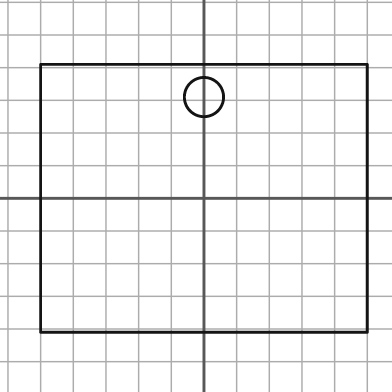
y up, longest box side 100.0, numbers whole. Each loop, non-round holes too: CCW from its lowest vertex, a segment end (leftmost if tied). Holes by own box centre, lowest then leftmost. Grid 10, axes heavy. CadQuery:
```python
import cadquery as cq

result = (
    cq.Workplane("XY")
    .moveTo(-50.0, -41.0)
    .lineTo(50.0, -41.0)
    .lineTo(50.0, 41.0)
    .lineTo(-50.0, 41.0)
    .close()
    .moveTo(0.0, 31.0)
    .circle(6.0)
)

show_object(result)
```